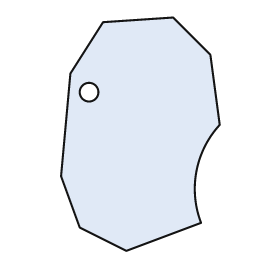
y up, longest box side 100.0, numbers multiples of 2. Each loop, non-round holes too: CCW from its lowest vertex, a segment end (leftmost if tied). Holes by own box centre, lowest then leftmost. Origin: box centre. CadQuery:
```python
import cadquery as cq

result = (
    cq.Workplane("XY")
    .moveTo(-6.0, -50.0)
    .lineTo(26.0, -38.0)
    .threePointArc((24.0, -16.0), (34.0, 4.0))
    .lineTo(30.0, 34.0)
    .lineTo(14.0, 50.0)
    .lineTo(-16.0, 48.0)
    .lineTo(-30.0, 26.0)
    .lineTo(-34.0, -18.0)
    .lineTo(-26.0, -40.0)
    .close()
    .moveTo(-22.0, 18.0)
    .circle(4.0)
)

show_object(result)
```